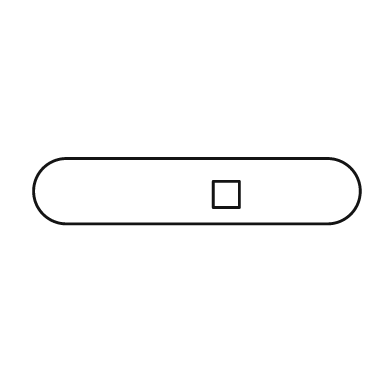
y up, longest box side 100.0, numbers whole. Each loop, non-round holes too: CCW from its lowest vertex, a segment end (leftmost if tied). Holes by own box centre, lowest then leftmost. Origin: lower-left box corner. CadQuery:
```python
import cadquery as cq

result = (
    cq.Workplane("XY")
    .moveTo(10.0, 0.0)
    .lineTo(90.0, 0.0)
    .threePointArc((100.0, 10.0), (90.0, 20.0))
    .lineTo(10.0, 20.0)
    .threePointArc((0.0, 10.0), (10.0, 0.0))
    .close()
    .moveTo(55.0, 5.0)
    .lineTo(63.0, 5.0)
    .lineTo(63.0, 13.0)
    .lineTo(55.0, 13.0)
    .close()
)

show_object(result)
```